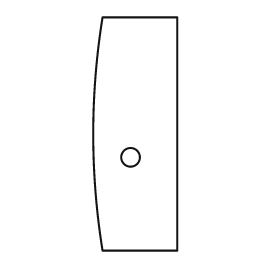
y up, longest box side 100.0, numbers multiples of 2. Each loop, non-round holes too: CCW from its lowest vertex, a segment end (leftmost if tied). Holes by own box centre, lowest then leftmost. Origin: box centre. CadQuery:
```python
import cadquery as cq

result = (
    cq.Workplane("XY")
    .moveTo(-14.0, -50.0)
    .lineTo(18.0, -50.0)
    .lineTo(18.0, 50.0)
    .lineTo(-14.0, 50.0)
    .threePointArc((-18.0, 0.0), (-14.0, -50.0))
    .close()
    .moveTo(-2.0, -10.0)
    .circle(4.0)
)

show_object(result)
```